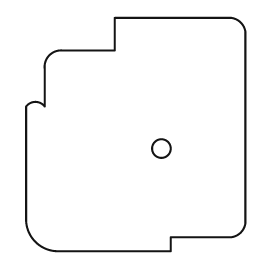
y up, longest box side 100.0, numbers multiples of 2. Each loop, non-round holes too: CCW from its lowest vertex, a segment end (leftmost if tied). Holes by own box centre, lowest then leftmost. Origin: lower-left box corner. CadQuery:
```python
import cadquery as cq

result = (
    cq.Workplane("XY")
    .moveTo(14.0, 0.0)
    .lineTo(62.0, 0.0)
    .lineTo(62.0, 6.0)
    .lineTo(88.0, 6.0)
    .threePointArc((92.0, 8.0), (94.0, 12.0))
    .lineTo(94.0, 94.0)
    .threePointArc((92.0, 98.0), (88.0, 100.0))
    .lineTo(38.0, 100.0)
    .lineTo(38.0, 86.0)
    .lineTo(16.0, 86.0)
    .threePointArc((10.0, 84.0), (8.0, 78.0))
    .lineTo(8.0, 62.0)
    .threePointArc((4.0, 64.0), (0.0, 62.0))
    .lineTo(0.0, 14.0)
    .threePointArc((4.0, 4.0), (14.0, 0.0))
    .close()
    .moveTo(58.0, 44.0)
    .circle(4.0)
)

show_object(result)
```